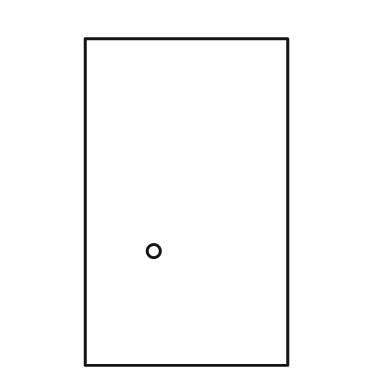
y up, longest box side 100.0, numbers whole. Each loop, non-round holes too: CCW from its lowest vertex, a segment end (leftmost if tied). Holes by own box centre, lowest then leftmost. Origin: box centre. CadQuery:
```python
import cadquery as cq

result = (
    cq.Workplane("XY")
    .moveTo(-31.0, -50.0)
    .lineTo(31.0, -50.0)
    .lineTo(31.0, 50.0)
    .lineTo(-31.0, 50.0)
    .close()
    .moveTo(-10.0, -15.0)
    .circle(2.0)
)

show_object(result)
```